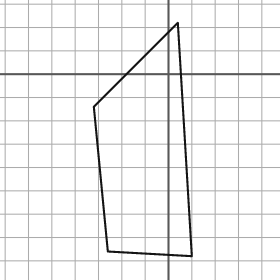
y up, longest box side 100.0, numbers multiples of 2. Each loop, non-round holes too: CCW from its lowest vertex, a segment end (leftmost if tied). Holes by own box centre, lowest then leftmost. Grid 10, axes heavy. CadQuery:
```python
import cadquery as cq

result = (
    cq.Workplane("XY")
    .moveTo(10.0, -78.0)
    .lineTo(4.0, 22.0)
    .lineTo(-32.0, -14.0)
    .lineTo(-26.0, -76.0)
    .close()
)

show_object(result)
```